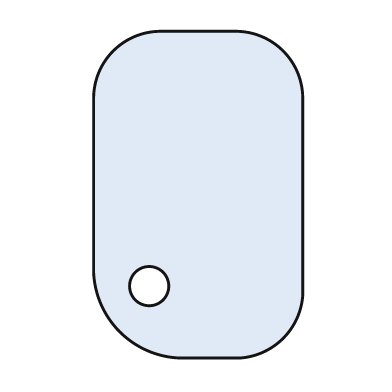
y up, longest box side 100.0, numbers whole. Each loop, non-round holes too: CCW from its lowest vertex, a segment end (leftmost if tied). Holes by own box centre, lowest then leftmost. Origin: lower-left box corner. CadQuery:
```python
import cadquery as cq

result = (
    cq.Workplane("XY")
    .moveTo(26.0, 0.0)
    .lineTo(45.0, 0.0)
    .threePointArc((58.0, 6.0), (64.0, 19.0))
    .lineTo(64.0, 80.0)
    .threePointArc((58.0, 94.0), (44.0, 100.0))
    .lineTo(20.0, 100.0)
    .threePointArc((6.0, 94.0), (0.0, 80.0))
    .lineTo(0.0, 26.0)
    .threePointArc((8.0, 8.0), (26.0, 0.0))
    .close()
    .moveTo(17.0, 22.0)
    .circle(6.0)
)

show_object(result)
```